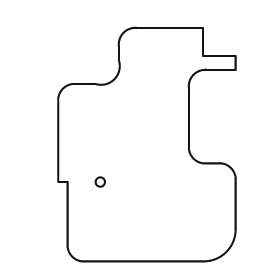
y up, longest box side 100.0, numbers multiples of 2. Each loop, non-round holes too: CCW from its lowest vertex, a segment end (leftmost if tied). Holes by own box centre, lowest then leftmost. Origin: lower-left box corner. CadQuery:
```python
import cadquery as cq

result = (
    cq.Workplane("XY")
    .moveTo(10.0, 0.0)
    .lineTo(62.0, 0.0)
    .threePointArc((72.0, 4.0), (76.0, 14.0))
    .lineTo(76.0, 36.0)
    .threePointArc((74.0, 40.0), (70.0, 42.0))
    .lineTo(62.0, 42.0)
    .threePointArc((58.0, 44.0), (56.0, 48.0))
    .lineTo(56.0, 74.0)
    .threePointArc((58.0, 80.0), (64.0, 82.0))
    .lineTo(76.0, 82.0)
    .lineTo(76.0, 88.0)
    .lineTo(62.0, 88.0)
    .lineTo(62.0, 100.0)
    .lineTo(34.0, 100.0)
    .threePointArc((28.0, 98.0), (26.0, 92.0))
    .lineTo(26.0, 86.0)
    .threePointArc((24.0, 78.0), (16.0, 76.0))
    .lineTo(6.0, 76.0)
    .threePointArc((2.0, 74.0), (0.0, 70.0))
    .lineTo(0.0, 34.0)
    .lineTo(4.0, 34.0)
    .lineTo(4.0, 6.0)
    .threePointArc((6.0, 2.0), (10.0, 0.0))
    .close()
    .moveTo(18.0, 34.0)
    .circle(2.0)
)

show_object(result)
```